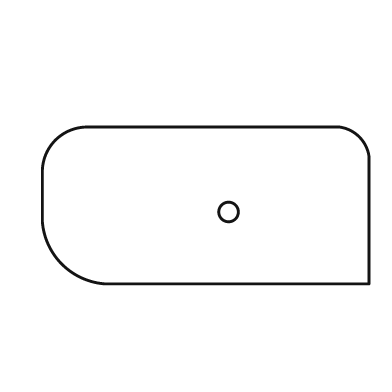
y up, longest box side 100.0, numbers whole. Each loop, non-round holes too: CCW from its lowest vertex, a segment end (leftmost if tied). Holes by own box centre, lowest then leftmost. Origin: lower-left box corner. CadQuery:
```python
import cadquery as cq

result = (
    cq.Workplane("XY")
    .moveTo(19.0, 0.0)
    .lineTo(100.0, 0.0)
    .lineTo(100.0, 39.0)
    .threePointArc((97.0, 45.0), (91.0, 48.0))
    .lineTo(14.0, 48.0)
    .threePointArc((4.0, 44.0), (0.0, 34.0))
    .lineTo(0.0, 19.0)
    .threePointArc((6.0, 6.0), (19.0, 0.0))
    .close()
    .moveTo(57.0, 22.0)
    .circle(3.0)
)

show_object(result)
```